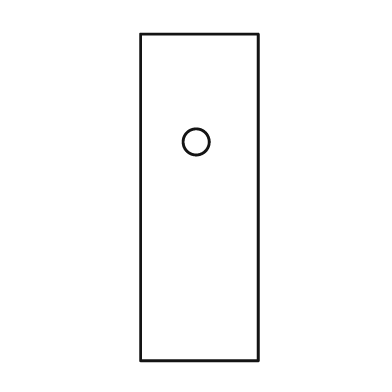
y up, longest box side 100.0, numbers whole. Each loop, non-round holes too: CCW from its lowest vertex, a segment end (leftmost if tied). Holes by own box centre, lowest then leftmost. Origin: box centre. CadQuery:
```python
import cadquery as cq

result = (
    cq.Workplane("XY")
    .moveTo(-18.0, -50.0)
    .lineTo(18.0, -50.0)
    .lineTo(18.0, 50.0)
    .lineTo(-18.0, 50.0)
    .close()
    .moveTo(-1.0, 17.0)
    .circle(4.0)
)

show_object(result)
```